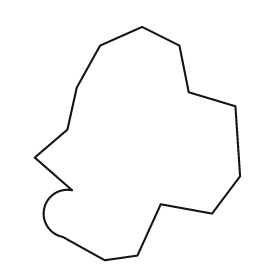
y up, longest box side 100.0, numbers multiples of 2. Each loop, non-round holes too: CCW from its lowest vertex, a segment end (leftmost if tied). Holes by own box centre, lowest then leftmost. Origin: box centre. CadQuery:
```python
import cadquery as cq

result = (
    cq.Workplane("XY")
    .moveTo(-14.0, -50.0)
    .lineTo(0.0, -48.0)
    .lineTo(10.0, -26.0)
    .lineTo(32.0, -30.0)
    .lineTo(44.0, -14.0)
    .lineTo(42.0, 16.0)
    .lineTo(22.0, 22.0)
    .lineTo(18.0, 42.0)
    .lineTo(2.0, 50.0)
    .lineTo(-16.0, 42.0)
    .lineTo(-26.0, 24.0)
    .lineTo(-30.0, 6.0)
    .lineTo(-44.0, -6.0)
    .lineTo(-28.0, -20.0)
    .threePointArc((-40.0, -28.0), (-32.0, -40.0))
    .close()
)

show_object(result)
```